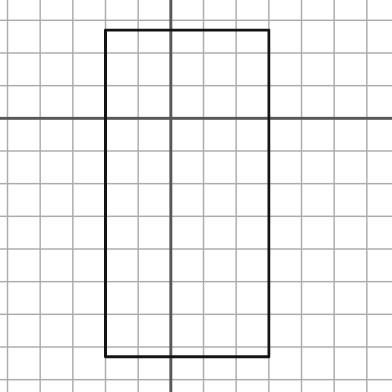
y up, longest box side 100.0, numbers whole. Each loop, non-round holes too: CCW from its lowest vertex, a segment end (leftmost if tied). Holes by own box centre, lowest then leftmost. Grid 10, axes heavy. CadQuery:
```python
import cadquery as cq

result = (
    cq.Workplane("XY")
    .moveTo(-20.0, -73.0)
    .lineTo(30.0, -73.0)
    .lineTo(30.0, 27.0)
    .lineTo(-20.0, 27.0)
    .close()
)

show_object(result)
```